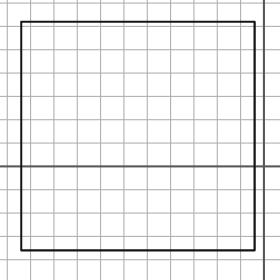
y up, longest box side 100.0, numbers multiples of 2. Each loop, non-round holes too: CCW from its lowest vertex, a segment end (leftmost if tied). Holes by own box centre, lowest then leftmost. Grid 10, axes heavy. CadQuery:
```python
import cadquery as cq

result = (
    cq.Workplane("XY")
    .moveTo(-104.0, -36.0)
    .lineTo(-4.0, -36.0)
    .lineTo(-4.0, 62.0)
    .lineTo(-104.0, 62.0)
    .close()
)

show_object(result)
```